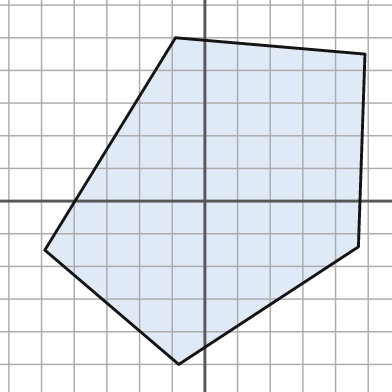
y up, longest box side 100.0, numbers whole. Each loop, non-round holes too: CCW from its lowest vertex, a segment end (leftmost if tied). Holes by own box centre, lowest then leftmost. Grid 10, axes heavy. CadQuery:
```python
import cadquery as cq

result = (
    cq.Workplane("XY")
    .moveTo(-8.0, -50.0)
    .lineTo(47.0, -14.0)
    .lineTo(49.0, 45.0)
    .lineTo(-9.0, 50.0)
    .lineTo(-49.0, -15.0)
    .close()
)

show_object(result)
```